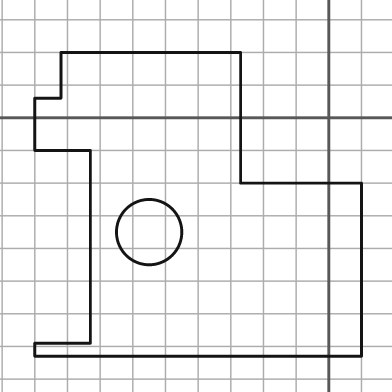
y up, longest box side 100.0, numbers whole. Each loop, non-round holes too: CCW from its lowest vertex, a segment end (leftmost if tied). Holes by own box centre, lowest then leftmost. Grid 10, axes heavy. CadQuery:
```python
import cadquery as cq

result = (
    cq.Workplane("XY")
    .moveTo(-90.0, -73.0)
    .lineTo(10.0, -73.0)
    .lineTo(10.0, -20.0)
    .lineTo(-27.0, -20.0)
    .lineTo(-27.0, 20.0)
    .lineTo(-82.0, 20.0)
    .lineTo(-82.0, 6.0)
    .lineTo(-90.0, 6.0)
    .lineTo(-90.0, -10.0)
    .lineTo(-73.0, -10.0)
    .lineTo(-73.0, -69.0)
    .lineTo(-90.0, -69.0)
    .close()
    .moveTo(-55.0, -35.0)
    .circle(10.0)
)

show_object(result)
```